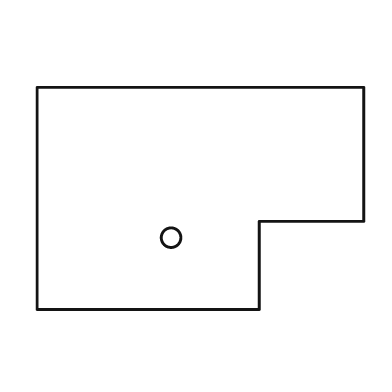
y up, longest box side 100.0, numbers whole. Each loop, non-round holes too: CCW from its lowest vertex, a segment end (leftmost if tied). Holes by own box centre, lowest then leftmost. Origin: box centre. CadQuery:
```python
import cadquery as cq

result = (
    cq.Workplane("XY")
    .moveTo(-50.0, -34.0)
    .lineTo(18.0, -34.0)
    .lineTo(18.0, -7.0)
    .lineTo(50.0, -7.0)
    .lineTo(50.0, 34.0)
    .lineTo(-50.0, 34.0)
    .close()
    .moveTo(-9.0, -12.0)
    .circle(3.0)
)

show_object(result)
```